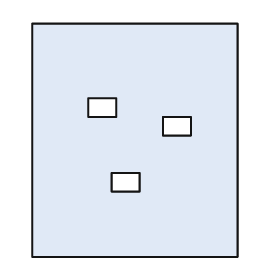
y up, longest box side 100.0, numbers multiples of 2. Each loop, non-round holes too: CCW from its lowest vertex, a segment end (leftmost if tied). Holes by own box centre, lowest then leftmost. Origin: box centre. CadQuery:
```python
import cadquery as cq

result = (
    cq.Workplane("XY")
    .moveTo(-44.0, -50.0)
    .lineTo(44.0, -50.0)
    .lineTo(44.0, 50.0)
    .lineTo(-44.0, 50.0)
    .close()
    .moveTo(-10.0, -22.0)
    .lineTo(2.0, -22.0)
    .lineTo(2.0, -14.0)
    .lineTo(-10.0, -14.0)
    .close()
    .moveTo(12.0, 2.0)
    .lineTo(24.0, 2.0)
    .lineTo(24.0, 10.0)
    .lineTo(12.0, 10.0)
    .close()
    .moveTo(-20.0, 10.0)
    .lineTo(-8.0, 10.0)
    .lineTo(-8.0, 18.0)
    .lineTo(-20.0, 18.0)
    .close()
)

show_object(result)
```